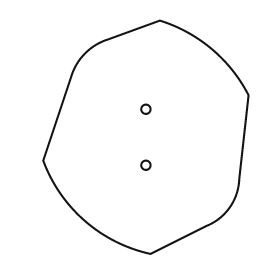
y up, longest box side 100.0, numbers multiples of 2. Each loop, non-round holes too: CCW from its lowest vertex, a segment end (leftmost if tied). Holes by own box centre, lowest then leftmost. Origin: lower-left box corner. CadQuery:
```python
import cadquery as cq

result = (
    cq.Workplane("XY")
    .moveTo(46.0, 0.0)
    .lineTo(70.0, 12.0)
    .threePointArc((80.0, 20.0), (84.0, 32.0))
    .lineTo(88.0, 68.0)
    .threePointArc((72.0, 88.0), (50.0, 100.0))
    .lineTo(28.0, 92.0)
    .threePointArc((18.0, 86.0), (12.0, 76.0))
    .lineTo(0.0, 40.0)
    .threePointArc((18.0, 14.0), (46.0, 0.0))
    .close()
    .moveTo(44.0, 38.0)
    .circle(2.0)
    .moveTo(44.0, 62.0)
    .circle(2.0)
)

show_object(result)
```